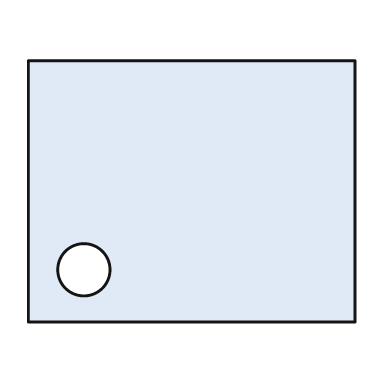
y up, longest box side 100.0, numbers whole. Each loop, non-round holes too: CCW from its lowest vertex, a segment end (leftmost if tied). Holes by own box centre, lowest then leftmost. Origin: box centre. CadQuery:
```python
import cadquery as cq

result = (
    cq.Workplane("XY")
    .moveTo(-50.0, -40.0)
    .lineTo(50.0, -40.0)
    .lineTo(50.0, 40.0)
    .lineTo(-50.0, 40.0)
    .close()
    .moveTo(-33.0, -24.0)
    .circle(8.0)
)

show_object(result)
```